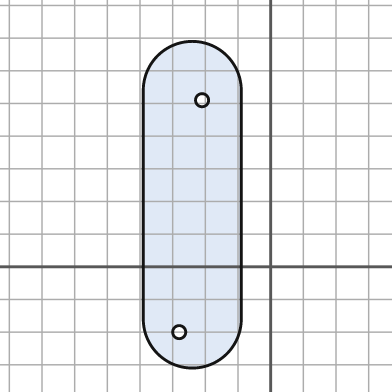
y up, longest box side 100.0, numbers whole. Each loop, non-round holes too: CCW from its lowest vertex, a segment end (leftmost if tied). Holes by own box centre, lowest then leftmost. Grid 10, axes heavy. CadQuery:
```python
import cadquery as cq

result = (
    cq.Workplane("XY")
    .moveTo(-39.0, -16.0)
    .threePointArc((-24.0, -31.0), (-9.0, -16.0))
    .lineTo(-9.0, 54.0)
    .threePointArc((-24.0, 69.0), (-39.0, 54.0))
    .close()
    .moveTo(-28.0, -20.0)
    .circle(2.0)
    .moveTo(-21.0, 51.0)
    .circle(2.0)
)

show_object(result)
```